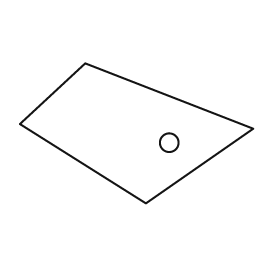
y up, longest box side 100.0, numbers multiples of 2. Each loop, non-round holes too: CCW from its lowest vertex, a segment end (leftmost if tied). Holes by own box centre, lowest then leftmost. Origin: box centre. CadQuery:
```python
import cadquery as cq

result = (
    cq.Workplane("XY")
    .moveTo(4.0, -30.0)
    .lineTo(50.0, 2.0)
    .lineTo(-22.0, 30.0)
    .lineTo(-50.0, 4.0)
    .close()
    .moveTo(14.0, -4.0)
    .circle(4.0)
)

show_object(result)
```